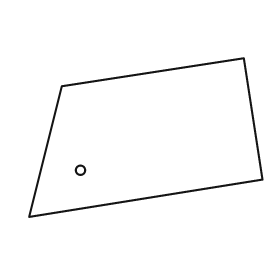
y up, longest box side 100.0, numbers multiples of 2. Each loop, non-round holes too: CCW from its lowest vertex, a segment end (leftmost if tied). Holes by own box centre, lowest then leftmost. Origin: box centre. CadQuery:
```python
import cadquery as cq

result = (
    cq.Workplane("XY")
    .moveTo(-50.0, -34.0)
    .lineTo(50.0, -18.0)
    .lineTo(42.0, 34.0)
    .lineTo(-36.0, 22.0)
    .close()
    .moveTo(-28.0, -14.0)
    .circle(2.0)
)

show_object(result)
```